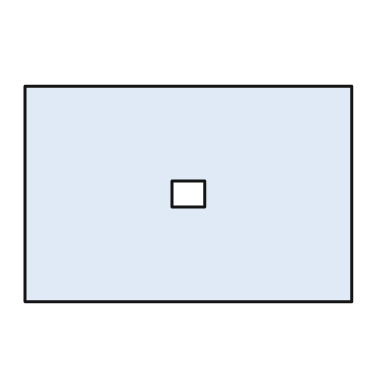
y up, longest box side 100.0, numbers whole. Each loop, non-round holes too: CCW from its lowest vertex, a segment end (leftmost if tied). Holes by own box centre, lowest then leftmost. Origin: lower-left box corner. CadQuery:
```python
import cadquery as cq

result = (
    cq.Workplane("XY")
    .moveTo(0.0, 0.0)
    .lineTo(100.0, 0.0)
    .lineTo(100.0, 66.0)
    .lineTo(0.0, 66.0)
    .close()
    .moveTo(45.0, 29.0)
    .lineTo(55.0, 29.0)
    .lineTo(55.0, 37.0)
    .lineTo(45.0, 37.0)
    .close()
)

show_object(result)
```